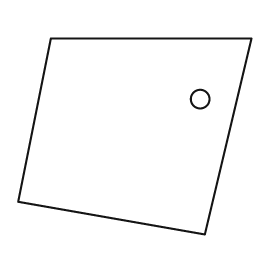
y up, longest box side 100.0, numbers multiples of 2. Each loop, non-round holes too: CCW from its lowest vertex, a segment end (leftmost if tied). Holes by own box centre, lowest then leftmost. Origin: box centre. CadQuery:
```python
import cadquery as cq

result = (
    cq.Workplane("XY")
    .moveTo(30.0, -42.0)
    .lineTo(50.0, 42.0)
    .lineTo(-36.0, 42.0)
    .lineTo(-50.0, -28.0)
    .close()
    .moveTo(28.0, 16.0)
    .circle(4.0)
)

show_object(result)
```